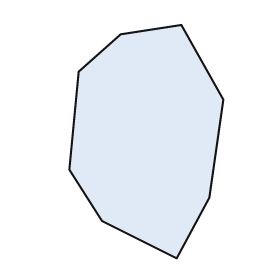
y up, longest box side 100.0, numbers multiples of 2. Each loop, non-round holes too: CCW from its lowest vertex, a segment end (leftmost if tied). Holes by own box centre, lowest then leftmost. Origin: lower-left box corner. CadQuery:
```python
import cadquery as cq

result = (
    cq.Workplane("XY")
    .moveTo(46.0, 0.0)
    .lineTo(60.0, 26.0)
    .lineTo(66.0, 68.0)
    .lineTo(48.0, 100.0)
    .lineTo(22.0, 96.0)
    .lineTo(4.0, 80.0)
    .lineTo(0.0, 38.0)
    .lineTo(14.0, 16.0)
    .close()
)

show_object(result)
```